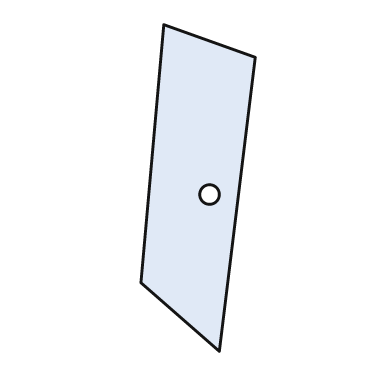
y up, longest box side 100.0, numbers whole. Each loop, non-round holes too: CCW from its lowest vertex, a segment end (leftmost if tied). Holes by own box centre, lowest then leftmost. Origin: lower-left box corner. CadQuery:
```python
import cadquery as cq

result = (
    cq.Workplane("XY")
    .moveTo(24.0, 0.0)
    .lineTo(35.0, 90.0)
    .lineTo(7.0, 100.0)
    .lineTo(0.0, 21.0)
    .close()
    .moveTo(21.0, 48.0)
    .circle(3.0)
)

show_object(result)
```